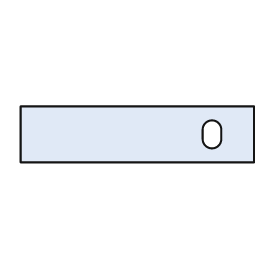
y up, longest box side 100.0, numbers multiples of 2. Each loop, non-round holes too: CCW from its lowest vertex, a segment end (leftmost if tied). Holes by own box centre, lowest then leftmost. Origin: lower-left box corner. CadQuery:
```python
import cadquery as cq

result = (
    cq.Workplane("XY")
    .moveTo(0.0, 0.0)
    .lineTo(100.0, 0.0)
    .lineTo(100.0, 24.0)
    .lineTo(0.0, 24.0)
    .close()
    .moveTo(78.0, 10.0)
    .threePointArc((82.0, 6.0), (86.0, 10.0))
    .lineTo(86.0, 14.0)
    .threePointArc((82.0, 18.0), (78.0, 14.0))
    .close()
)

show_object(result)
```